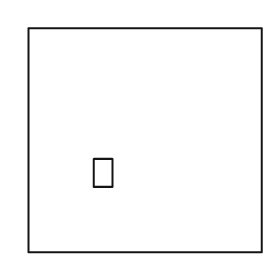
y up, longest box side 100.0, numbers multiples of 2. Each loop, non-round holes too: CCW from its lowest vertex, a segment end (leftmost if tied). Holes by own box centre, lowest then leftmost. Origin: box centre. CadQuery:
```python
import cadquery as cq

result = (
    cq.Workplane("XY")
    .moveTo(-50.0, -48.0)
    .lineTo(50.0, -48.0)
    .lineTo(50.0, 48.0)
    .lineTo(-50.0, 48.0)
    .close()
    .moveTo(-22.0, -20.0)
    .lineTo(-14.0, -20.0)
    .lineTo(-14.0, -8.0)
    .lineTo(-22.0, -8.0)
    .close()
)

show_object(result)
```